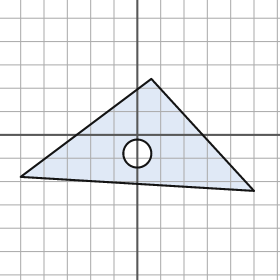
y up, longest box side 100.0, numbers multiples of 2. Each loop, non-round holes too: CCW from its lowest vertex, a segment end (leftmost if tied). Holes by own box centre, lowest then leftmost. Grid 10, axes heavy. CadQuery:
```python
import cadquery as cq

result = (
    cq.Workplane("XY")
    .moveTo(50.0, -24.0)
    .lineTo(6.0, 24.0)
    .lineTo(-50.0, -18.0)
    .close()
    .moveTo(0.0, -8.0)
    .circle(6.0)
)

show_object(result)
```